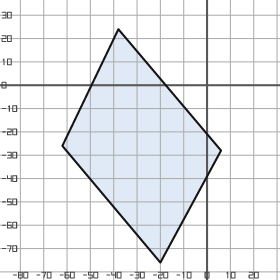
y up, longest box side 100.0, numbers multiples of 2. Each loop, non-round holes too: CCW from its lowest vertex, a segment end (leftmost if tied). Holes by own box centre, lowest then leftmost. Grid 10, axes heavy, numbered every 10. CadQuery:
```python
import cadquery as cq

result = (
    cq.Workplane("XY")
    .moveTo(-20.0, -76.0)
    .lineTo(6.0, -28.0)
    .lineTo(-38.0, 24.0)
    .lineTo(-62.0, -26.0)
    .close()
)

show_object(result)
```